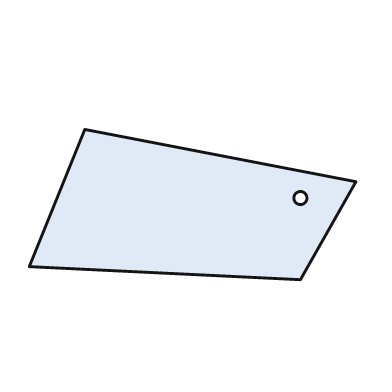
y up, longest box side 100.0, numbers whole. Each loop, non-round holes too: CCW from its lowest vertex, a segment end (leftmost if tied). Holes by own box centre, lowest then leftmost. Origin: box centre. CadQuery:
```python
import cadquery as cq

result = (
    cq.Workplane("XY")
    .moveTo(33.0, -23.0)
    .lineTo(50.0, 7.0)
    .lineTo(-33.0, 23.0)
    .lineTo(-50.0, -19.0)
    .close()
    .moveTo(33.0, 2.0)
    .circle(2.0)
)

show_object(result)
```